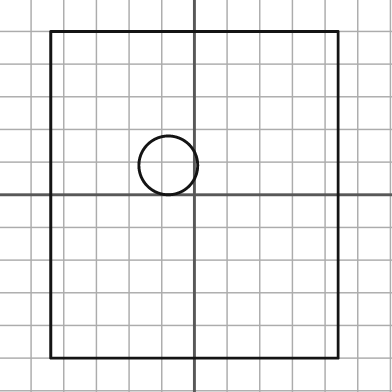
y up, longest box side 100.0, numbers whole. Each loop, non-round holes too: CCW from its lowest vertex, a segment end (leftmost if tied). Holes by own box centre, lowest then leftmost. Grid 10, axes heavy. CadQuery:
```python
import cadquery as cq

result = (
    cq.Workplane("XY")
    .moveTo(-44.0, -50.0)
    .lineTo(44.0, -50.0)
    .lineTo(44.0, 50.0)
    .lineTo(-44.0, 50.0)
    .close()
    .moveTo(-8.0, 9.0)
    .circle(9.0)
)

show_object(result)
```